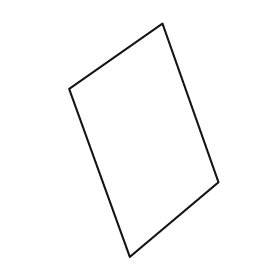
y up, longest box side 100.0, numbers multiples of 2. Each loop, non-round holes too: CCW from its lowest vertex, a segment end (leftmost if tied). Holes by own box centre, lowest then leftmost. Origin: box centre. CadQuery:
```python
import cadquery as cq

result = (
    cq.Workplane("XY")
    .moveTo(-6.0, -50.0)
    .lineTo(32.0, -18.0)
    .lineTo(8.0, 50.0)
    .lineTo(-32.0, 22.0)
    .close()
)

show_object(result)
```